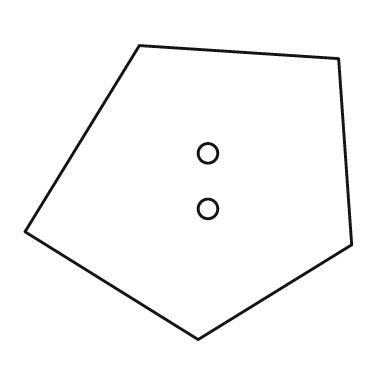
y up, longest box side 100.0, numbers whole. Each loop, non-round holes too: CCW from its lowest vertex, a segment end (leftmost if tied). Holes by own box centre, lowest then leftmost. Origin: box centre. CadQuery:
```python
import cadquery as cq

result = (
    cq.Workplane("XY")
    .moveTo(3.0, -45.0)
    .lineTo(50.0, -16.0)
    .lineTo(46.0, 41.0)
    .lineTo(-15.0, 45.0)
    .lineTo(-50.0, -12.0)
    .close()
    .moveTo(6.0, -5.0)
    .circle(3.0)
    .moveTo(6.0, 12.0)
    .circle(3.0)
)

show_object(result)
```